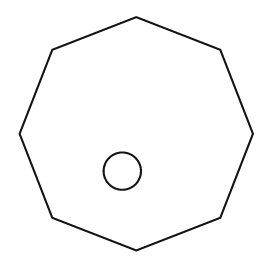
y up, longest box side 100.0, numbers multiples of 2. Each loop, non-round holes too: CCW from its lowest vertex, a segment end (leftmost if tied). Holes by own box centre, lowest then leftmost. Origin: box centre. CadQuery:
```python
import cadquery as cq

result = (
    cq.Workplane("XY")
    .moveTo(0.0, -50.0)
    .lineTo(36.0, -36.0)
    .lineTo(50.0, 0.0)
    .lineTo(36.0, 36.0)
    .lineTo(0.0, 50.0)
    .lineTo(-36.0, 36.0)
    .lineTo(-50.0, 0.0)
    .lineTo(-36.0, -36.0)
    .close()
    .moveTo(-6.0, -16.0)
    .circle(8.0)
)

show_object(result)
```